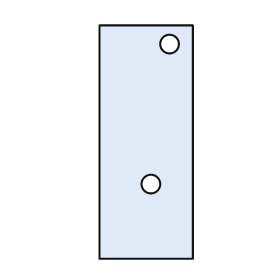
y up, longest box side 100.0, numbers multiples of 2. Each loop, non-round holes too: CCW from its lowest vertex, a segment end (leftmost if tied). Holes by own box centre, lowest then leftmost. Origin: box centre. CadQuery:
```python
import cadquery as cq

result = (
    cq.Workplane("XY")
    .moveTo(-20.0, -50.0)
    .lineTo(20.0, -50.0)
    .lineTo(20.0, 50.0)
    .lineTo(-20.0, 50.0)
    .close()
    .moveTo(2.0, -18.0)
    .circle(4.0)
    .moveTo(10.0, 42.0)
    .circle(4.0)
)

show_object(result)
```